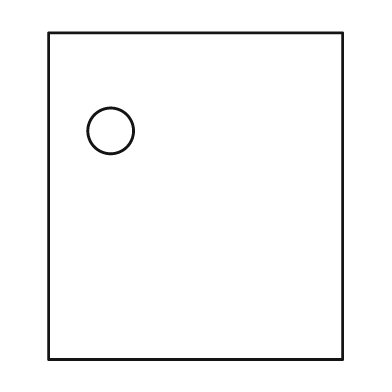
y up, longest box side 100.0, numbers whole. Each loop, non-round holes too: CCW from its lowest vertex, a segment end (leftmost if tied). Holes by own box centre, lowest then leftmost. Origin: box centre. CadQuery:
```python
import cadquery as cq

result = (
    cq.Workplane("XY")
    .moveTo(-45.0, -50.0)
    .lineTo(45.0, -50.0)
    .lineTo(45.0, 50.0)
    .lineTo(-45.0, 50.0)
    .close()
    .moveTo(-26.0, 20.0)
    .circle(7.0)
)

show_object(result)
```